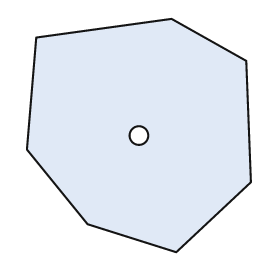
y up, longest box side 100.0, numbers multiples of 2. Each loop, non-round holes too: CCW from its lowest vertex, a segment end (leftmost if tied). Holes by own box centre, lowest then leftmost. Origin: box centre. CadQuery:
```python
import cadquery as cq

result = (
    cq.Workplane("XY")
    .moveTo(16.0, -50.0)
    .lineTo(48.0, -20.0)
    .lineTo(46.0, 32.0)
    .lineTo(14.0, 50.0)
    .lineTo(-44.0, 42.0)
    .lineTo(-48.0, -6.0)
    .lineTo(-22.0, -38.0)
    .close()
    .moveTo(0.0, 0.0)
    .circle(4.0)
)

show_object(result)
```